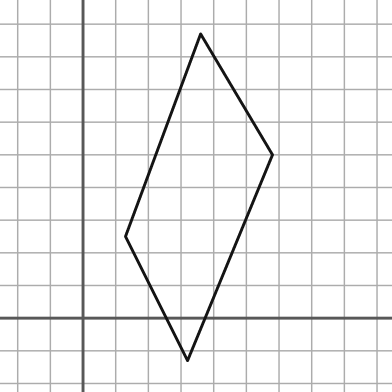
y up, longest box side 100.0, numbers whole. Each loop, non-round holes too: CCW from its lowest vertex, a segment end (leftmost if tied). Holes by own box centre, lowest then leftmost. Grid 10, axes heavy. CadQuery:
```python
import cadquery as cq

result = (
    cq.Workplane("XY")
    .moveTo(32.0, -13.0)
    .lineTo(58.0, 50.0)
    .lineTo(36.0, 87.0)
    .lineTo(13.0, 25.0)
    .close()
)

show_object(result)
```